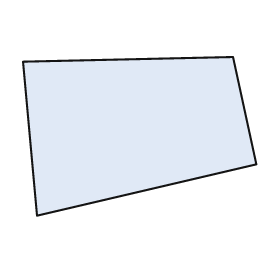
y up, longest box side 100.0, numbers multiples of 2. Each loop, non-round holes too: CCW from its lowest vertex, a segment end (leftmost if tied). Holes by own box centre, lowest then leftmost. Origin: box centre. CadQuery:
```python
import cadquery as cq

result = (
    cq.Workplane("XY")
    .moveTo(-44.0, -34.0)
    .lineTo(50.0, -12.0)
    .lineTo(40.0, 34.0)
    .lineTo(-50.0, 32.0)
    .close()
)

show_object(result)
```